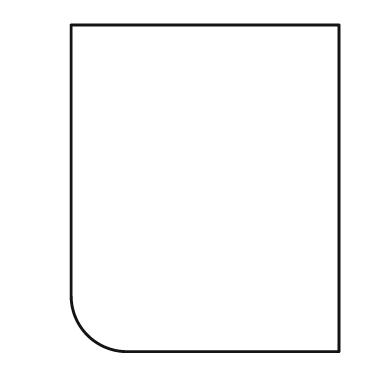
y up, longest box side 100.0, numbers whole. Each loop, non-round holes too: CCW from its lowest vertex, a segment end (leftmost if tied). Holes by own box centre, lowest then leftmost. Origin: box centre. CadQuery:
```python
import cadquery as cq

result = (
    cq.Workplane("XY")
    .moveTo(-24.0, -50.0)
    .lineTo(41.0, -50.0)
    .lineTo(41.0, 50.0)
    .lineTo(-41.0, 50.0)
    .lineTo(-41.0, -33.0)
    .threePointArc((-36.0, -45.0), (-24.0, -50.0))
    .close()
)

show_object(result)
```